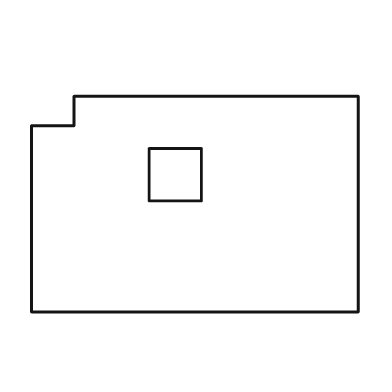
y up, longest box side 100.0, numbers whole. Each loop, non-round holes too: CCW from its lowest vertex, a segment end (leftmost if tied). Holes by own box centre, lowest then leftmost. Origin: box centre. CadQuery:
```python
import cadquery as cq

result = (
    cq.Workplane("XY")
    .moveTo(-50.0, -33.0)
    .lineTo(50.0, -33.0)
    .lineTo(50.0, 33.0)
    .lineTo(-37.0, 33.0)
    .lineTo(-37.0, 24.0)
    .lineTo(-50.0, 24.0)
    .close()
    .moveTo(-14.0, 1.0)
    .lineTo(2.0, 1.0)
    .lineTo(2.0, 17.0)
    .lineTo(-14.0, 17.0)
    .close()
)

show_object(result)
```